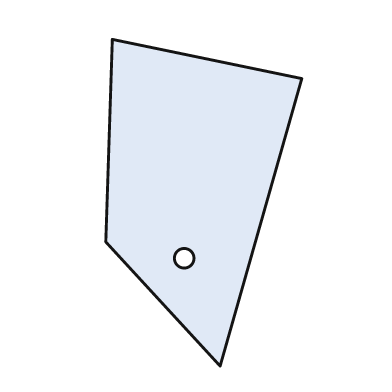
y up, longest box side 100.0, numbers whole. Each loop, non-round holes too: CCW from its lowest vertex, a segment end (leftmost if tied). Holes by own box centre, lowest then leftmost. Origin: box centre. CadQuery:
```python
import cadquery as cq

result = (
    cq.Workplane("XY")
    .moveTo(5.0, -50.0)
    .lineTo(30.0, 38.0)
    .lineTo(-28.0, 50.0)
    .lineTo(-30.0, -12.0)
    .close()
    .moveTo(-6.0, -17.0)
    .circle(3.0)
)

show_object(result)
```